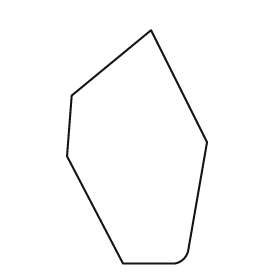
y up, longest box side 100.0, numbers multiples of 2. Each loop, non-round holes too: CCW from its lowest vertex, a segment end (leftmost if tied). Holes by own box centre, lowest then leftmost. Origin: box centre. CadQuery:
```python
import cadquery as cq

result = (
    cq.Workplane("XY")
    .moveTo(-6.0, -50.0)
    .lineTo(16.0, -50.0)
    .threePointArc((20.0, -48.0), (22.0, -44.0))
    .lineTo(30.0, 2.0)
    .lineTo(6.0, 50.0)
    .lineTo(-28.0, 22.0)
    .lineTo(-30.0, -4.0)
    .close()
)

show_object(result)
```